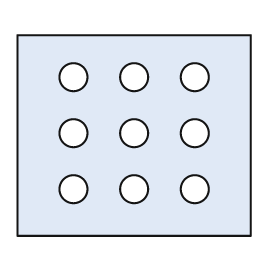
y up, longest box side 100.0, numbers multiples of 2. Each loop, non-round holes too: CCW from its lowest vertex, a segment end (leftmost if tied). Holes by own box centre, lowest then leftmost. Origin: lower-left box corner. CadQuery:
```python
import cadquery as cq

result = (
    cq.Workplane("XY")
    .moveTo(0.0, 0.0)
    .lineTo(100.0, 0.0)
    .lineTo(100.0, 86.0)
    .lineTo(0.0, 86.0)
    .close()
    .moveTo(24.0, 20.0)
    .circle(6.0)
    .moveTo(50.0, 20.0)
    .circle(6.0)
    .moveTo(76.0, 20.0)
    .circle(6.0)
    .moveTo(24.0, 44.0)
    .circle(6.0)
    .moveTo(50.0, 44.0)
    .circle(6.0)
    .moveTo(76.0, 44.0)
    .circle(6.0)
    .moveTo(24.0, 68.0)
    .circle(6.0)
    .moveTo(50.0, 68.0)
    .circle(6.0)
    .moveTo(76.0, 68.0)
    .circle(6.0)
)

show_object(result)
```